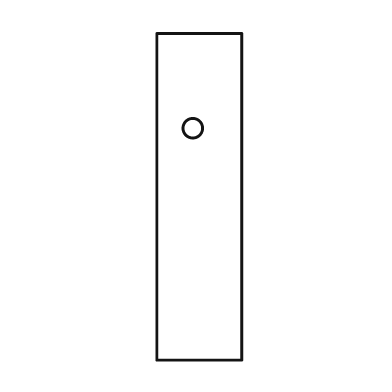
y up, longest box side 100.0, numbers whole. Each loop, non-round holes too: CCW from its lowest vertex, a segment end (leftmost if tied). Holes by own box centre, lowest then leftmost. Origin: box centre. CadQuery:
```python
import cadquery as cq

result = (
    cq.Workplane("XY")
    .moveTo(-13.0, -50.0)
    .lineTo(13.0, -50.0)
    .lineTo(13.0, 50.0)
    .lineTo(-13.0, 50.0)
    .close()
    .moveTo(-2.0, 21.0)
    .circle(3.0)
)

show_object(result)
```